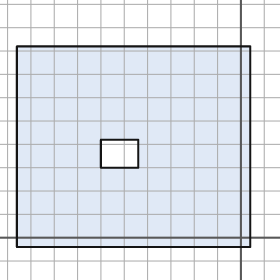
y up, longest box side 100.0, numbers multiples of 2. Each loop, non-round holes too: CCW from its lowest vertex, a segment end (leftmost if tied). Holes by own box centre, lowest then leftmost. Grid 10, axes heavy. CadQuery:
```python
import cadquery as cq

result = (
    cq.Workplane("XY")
    .moveTo(-96.0, -4.0)
    .lineTo(4.0, -4.0)
    .lineTo(4.0, 82.0)
    .lineTo(-96.0, 82.0)
    .close()
    .moveTo(-60.0, 30.0)
    .lineTo(-44.0, 30.0)
    .lineTo(-44.0, 42.0)
    .lineTo(-60.0, 42.0)
    .close()
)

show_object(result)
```